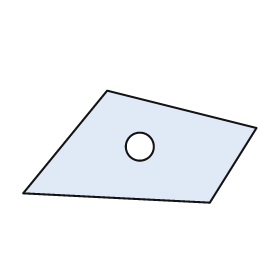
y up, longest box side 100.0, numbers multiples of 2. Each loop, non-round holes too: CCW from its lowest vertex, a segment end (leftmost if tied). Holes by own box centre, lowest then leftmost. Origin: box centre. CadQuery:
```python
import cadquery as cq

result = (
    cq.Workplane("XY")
    .moveTo(30.0, -24.0)
    .lineTo(50.0, 8.0)
    .lineTo(-14.0, 24.0)
    .lineTo(-50.0, -20.0)
    .close()
    .moveTo(0.0, 0.0)
    .circle(6.0)
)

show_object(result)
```